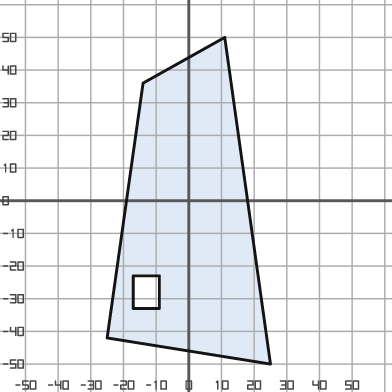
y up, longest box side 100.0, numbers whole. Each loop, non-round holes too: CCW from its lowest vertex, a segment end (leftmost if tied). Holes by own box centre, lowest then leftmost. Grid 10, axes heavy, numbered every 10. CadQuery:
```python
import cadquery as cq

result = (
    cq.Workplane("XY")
    .moveTo(25.0, -50.0)
    .lineTo(11.0, 50.0)
    .lineTo(-14.0, 36.0)
    .lineTo(-25.0, -42.0)
    .close()
    .moveTo(-17.0, -33.0)
    .lineTo(-9.0, -33.0)
    .lineTo(-9.0, -23.0)
    .lineTo(-17.0, -23.0)
    .close()
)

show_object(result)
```